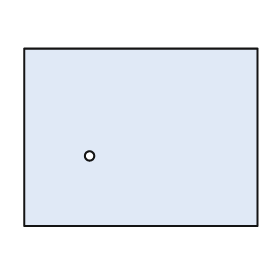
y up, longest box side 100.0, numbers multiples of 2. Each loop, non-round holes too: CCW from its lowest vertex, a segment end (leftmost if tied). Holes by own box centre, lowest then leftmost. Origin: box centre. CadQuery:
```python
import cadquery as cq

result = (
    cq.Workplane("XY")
    .moveTo(-50.0, -38.0)
    .lineTo(50.0, -38.0)
    .lineTo(50.0, 38.0)
    .lineTo(-50.0, 38.0)
    .close()
    .moveTo(-22.0, -8.0)
    .circle(2.0)
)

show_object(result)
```